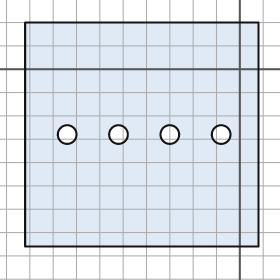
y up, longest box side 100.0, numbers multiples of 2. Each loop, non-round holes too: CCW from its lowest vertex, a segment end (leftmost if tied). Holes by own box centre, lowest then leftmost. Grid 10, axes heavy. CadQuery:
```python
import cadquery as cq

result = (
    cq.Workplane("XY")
    .moveTo(-92.0, -76.0)
    .lineTo(8.0, -76.0)
    .lineTo(8.0, 20.0)
    .lineTo(-92.0, 20.0)
    .close()
    .moveTo(-74.0, -28.0)
    .circle(4.0)
    .moveTo(-52.0, -28.0)
    .circle(4.0)
    .moveTo(-30.0, -28.0)
    .circle(4.0)
    .moveTo(-8.0, -28.0)
    .circle(4.0)
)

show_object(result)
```